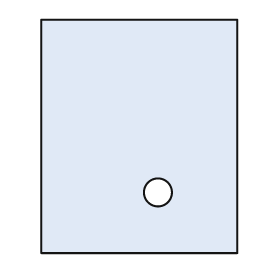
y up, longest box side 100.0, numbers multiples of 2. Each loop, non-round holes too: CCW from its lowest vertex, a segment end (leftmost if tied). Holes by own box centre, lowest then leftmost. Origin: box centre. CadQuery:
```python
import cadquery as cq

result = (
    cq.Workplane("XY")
    .moveTo(-42.0, -50.0)
    .lineTo(42.0, -50.0)
    .lineTo(42.0, 50.0)
    .lineTo(-42.0, 50.0)
    .close()
    .moveTo(8.0, -24.0)
    .circle(6.0)
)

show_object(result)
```